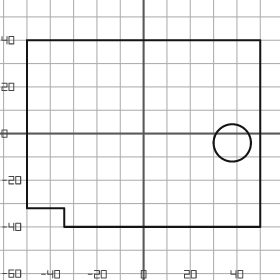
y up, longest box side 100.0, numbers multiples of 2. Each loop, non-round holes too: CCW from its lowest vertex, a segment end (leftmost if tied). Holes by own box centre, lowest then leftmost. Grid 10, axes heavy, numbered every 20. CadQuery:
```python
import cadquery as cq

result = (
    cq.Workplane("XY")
    .moveTo(-34.0, -40.0)
    .lineTo(50.0, -40.0)
    .lineTo(50.0, 40.0)
    .lineTo(-50.0, 40.0)
    .lineTo(-50.0, -32.0)
    .lineTo(-34.0, -32.0)
    .close()
    .moveTo(38.0, -4.0)
    .circle(8.0)
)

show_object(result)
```